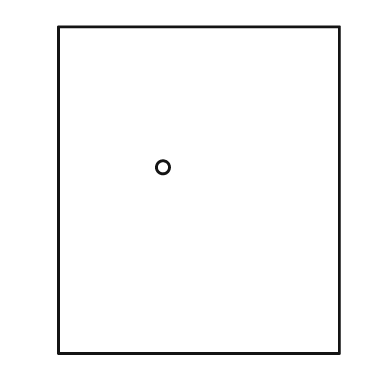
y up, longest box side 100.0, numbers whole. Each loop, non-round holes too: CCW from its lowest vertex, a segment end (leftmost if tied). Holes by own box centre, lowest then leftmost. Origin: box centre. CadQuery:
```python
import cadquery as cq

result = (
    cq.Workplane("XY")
    .moveTo(-43.0, -50.0)
    .lineTo(43.0, -50.0)
    .lineTo(43.0, 50.0)
    .lineTo(-43.0, 50.0)
    .close()
    .moveTo(-11.0, 7.0)
    .circle(2.0)
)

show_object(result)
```